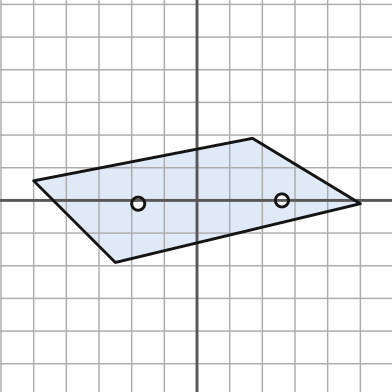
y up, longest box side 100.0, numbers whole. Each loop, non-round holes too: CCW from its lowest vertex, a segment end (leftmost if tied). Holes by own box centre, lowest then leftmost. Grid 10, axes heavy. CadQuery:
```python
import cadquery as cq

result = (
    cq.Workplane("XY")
    .moveTo(-25.0, -19.0)
    .lineTo(50.0, -1.0)
    .lineTo(17.0, 19.0)
    .lineTo(-50.0, 6.0)
    .close()
    .moveTo(-18.0, -1.0)
    .circle(2.0)
    .moveTo(26.0, 0.0)
    .circle(2.0)
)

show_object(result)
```